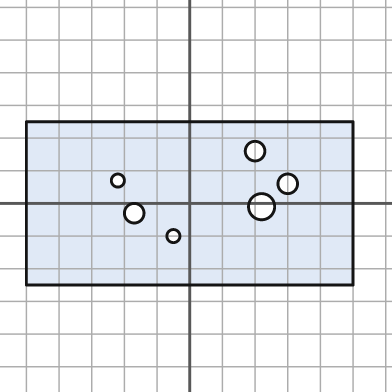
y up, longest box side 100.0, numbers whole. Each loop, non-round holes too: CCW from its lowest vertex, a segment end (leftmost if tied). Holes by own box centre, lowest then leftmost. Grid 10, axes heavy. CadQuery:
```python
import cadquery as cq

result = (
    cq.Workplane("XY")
    .moveTo(-50.0, -25.0)
    .lineTo(50.0, -25.0)
    .lineTo(50.0, 25.0)
    .lineTo(-50.0, 25.0)
    .close()
    .moveTo(-5.0, -10.0)
    .circle(2.0)
    .moveTo(-17.0, -3.0)
    .circle(3.0)
    .moveTo(22.0, -1.0)
    .circle(4.0)
    .moveTo(30.0, 6.0)
    .circle(3.0)
    .moveTo(-22.0, 7.0)
    .circle(2.0)
    .moveTo(20.0, 16.0)
    .circle(3.0)
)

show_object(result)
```